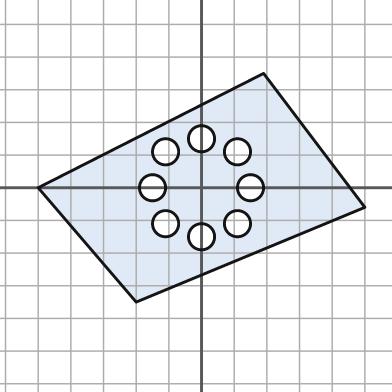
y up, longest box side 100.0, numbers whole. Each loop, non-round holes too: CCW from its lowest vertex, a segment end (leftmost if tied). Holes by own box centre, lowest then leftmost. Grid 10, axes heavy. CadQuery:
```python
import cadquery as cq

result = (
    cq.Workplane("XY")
    .moveTo(-20.0, -35.0)
    .lineTo(50.0, -6.0)
    .lineTo(19.0, 35.0)
    .lineTo(-50.0, 0.0)
    .close()
    .moveTo(0.0, -15.0)
    .circle(4.0)
    .moveTo(-11.0, -11.0)
    .circle(4.0)
    .moveTo(11.0, -11.0)
    .circle(4.0)
    .moveTo(-15.0, 0.0)
    .circle(4.0)
    .moveTo(15.0, 0.0)
    .circle(4.0)
    .moveTo(-11.0, 11.0)
    .circle(4.0)
    .moveTo(11.0, 11.0)
    .circle(4.0)
    .moveTo(0.0, 15.0)
    .circle(4.0)
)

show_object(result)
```